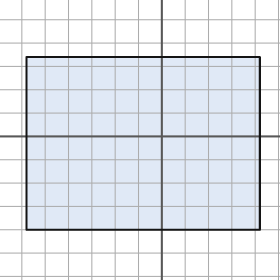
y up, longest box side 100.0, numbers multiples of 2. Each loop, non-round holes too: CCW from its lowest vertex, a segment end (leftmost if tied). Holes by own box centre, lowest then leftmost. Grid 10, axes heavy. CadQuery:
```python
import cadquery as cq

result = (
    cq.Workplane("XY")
    .moveTo(-58.0, -40.0)
    .lineTo(42.0, -40.0)
    .lineTo(42.0, 34.0)
    .lineTo(-58.0, 34.0)
    .close()
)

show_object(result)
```